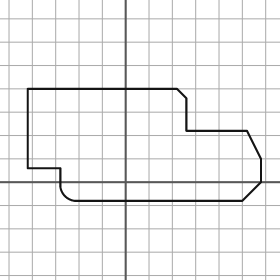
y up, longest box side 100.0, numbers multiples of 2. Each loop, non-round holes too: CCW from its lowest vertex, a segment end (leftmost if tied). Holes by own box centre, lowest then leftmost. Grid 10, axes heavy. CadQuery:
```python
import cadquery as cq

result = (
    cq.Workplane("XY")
    .moveTo(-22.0, -8.0)
    .lineTo(50.0, -8.0)
    .lineTo(58.0, 0.0)
    .lineTo(58.0, 10.0)
    .lineTo(52.0, 22.0)
    .lineTo(26.0, 22.0)
    .lineTo(26.0, 36.0)
    .lineTo(22.0, 40.0)
    .lineTo(-42.0, 40.0)
    .lineTo(-42.0, 6.0)
    .lineTo(-28.0, 6.0)
    .lineTo(-28.0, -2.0)
    .threePointArc((-26.0, -6.0), (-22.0, -8.0))
    .close()
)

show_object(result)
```